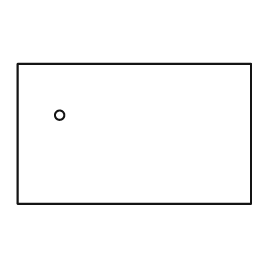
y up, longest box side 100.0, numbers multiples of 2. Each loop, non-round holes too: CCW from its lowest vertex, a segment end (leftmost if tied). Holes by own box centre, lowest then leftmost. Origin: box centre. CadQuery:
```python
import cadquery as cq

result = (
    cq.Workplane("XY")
    .moveTo(-50.0, -30.0)
    .lineTo(50.0, -30.0)
    .lineTo(50.0, 30.0)
    .lineTo(-50.0, 30.0)
    .close()
    .moveTo(-32.0, 8.0)
    .circle(2.0)
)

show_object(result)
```